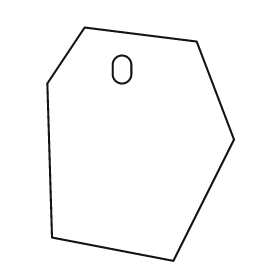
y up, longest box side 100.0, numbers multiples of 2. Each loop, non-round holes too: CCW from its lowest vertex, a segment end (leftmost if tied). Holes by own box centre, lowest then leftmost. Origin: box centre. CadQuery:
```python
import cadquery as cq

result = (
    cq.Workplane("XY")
    .moveTo(14.0, -50.0)
    .lineTo(40.0, 2.0)
    .lineTo(24.0, 44.0)
    .lineTo(-24.0, 50.0)
    .lineTo(-40.0, 26.0)
    .lineTo(-38.0, -40.0)
    .close()
    .moveTo(-12.0, 30.0)
    .threePointArc((-8.0, 26.0), (-4.0, 30.0))
    .lineTo(-4.0, 34.0)
    .threePointArc((-8.0, 38.0), (-12.0, 34.0))
    .close()
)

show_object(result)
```